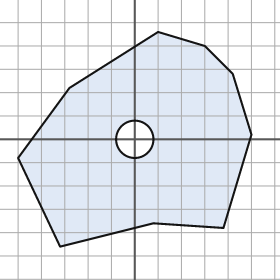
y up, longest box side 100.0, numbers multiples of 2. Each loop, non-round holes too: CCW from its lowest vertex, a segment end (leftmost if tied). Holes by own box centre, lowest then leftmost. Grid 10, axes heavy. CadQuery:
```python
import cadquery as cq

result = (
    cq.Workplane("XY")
    .moveTo(-32.0, -46.0)
    .lineTo(8.0, -36.0)
    .lineTo(38.0, -38.0)
    .lineTo(50.0, 2.0)
    .lineTo(42.0, 28.0)
    .lineTo(30.0, 40.0)
    .lineTo(10.0, 46.0)
    .lineTo(-28.0, 22.0)
    .lineTo(-50.0, -8.0)
    .close()
    .moveTo(0.0, 0.0)
    .circle(8.0)
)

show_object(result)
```